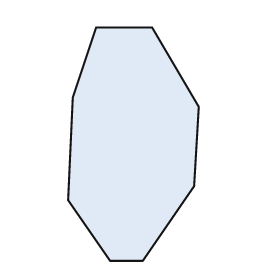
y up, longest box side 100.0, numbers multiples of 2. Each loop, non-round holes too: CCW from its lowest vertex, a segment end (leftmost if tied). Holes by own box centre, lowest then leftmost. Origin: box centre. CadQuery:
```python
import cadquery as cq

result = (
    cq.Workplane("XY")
    .moveTo(-10.0, -50.0)
    .lineTo(4.0, -50.0)
    .lineTo(26.0, -18.0)
    .lineTo(28.0, 16.0)
    .lineTo(8.0, 50.0)
    .lineTo(-16.0, 50.0)
    .lineTo(-26.0, 20.0)
    .lineTo(-28.0, -24.0)
    .close()
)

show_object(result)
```